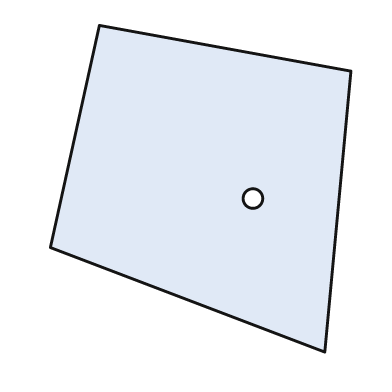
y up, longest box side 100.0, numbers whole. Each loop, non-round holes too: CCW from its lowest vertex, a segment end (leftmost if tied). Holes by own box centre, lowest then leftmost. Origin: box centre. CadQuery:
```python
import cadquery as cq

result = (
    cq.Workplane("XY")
    .moveTo(38.0, -50.0)
    .lineTo(46.0, 36.0)
    .lineTo(-31.0, 50.0)
    .lineTo(-46.0, -18.0)
    .close()
    .moveTo(16.0, -3.0)
    .circle(3.0)
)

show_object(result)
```